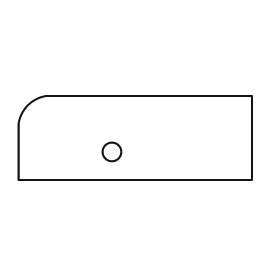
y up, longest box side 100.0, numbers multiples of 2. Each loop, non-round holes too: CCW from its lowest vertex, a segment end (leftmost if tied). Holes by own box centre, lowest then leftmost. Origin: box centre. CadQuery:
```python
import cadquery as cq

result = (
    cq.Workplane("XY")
    .moveTo(-50.0, -18.0)
    .lineTo(50.0, -18.0)
    .lineTo(50.0, 18.0)
    .lineTo(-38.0, 18.0)
    .threePointArc((-46.0, 14.0), (-50.0, 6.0))
    .close()
    .moveTo(-10.0, -6.0)
    .circle(4.0)
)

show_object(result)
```